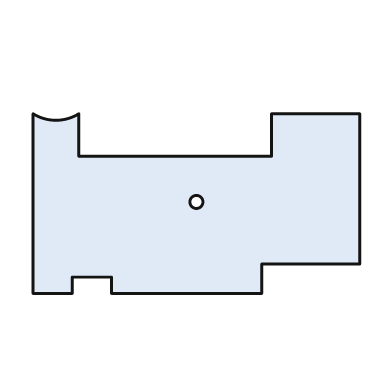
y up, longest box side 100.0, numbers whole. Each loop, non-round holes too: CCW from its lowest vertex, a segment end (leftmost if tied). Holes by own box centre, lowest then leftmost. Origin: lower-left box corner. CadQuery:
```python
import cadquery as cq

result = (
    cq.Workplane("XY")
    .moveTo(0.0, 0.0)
    .lineTo(12.0, 0.0)
    .lineTo(12.0, 5.0)
    .lineTo(24.0, 5.0)
    .lineTo(24.0, 0.0)
    .lineTo(70.0, 0.0)
    .lineTo(70.0, 9.0)
    .lineTo(100.0, 9.0)
    .lineTo(100.0, 55.0)
    .lineTo(73.0, 55.0)
    .lineTo(73.0, 42.0)
    .lineTo(14.0, 42.0)
    .lineTo(14.0, 55.0)
    .threePointArc((7.0, 53.0), (0.0, 55.0))
    .close()
    .moveTo(50.0, 28.0)
    .circle(2.0)
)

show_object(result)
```